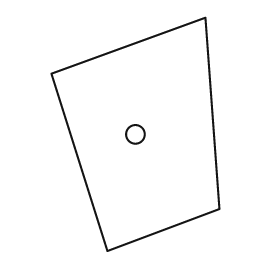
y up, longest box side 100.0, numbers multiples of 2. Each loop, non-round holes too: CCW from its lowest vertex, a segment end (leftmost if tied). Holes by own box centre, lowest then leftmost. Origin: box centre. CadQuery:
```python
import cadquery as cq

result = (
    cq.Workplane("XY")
    .moveTo(-12.0, -50.0)
    .lineTo(36.0, -32.0)
    .lineTo(30.0, 50.0)
    .lineTo(-36.0, 26.0)
    .close()
    .moveTo(0.0, 0.0)
    .circle(4.0)
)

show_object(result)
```